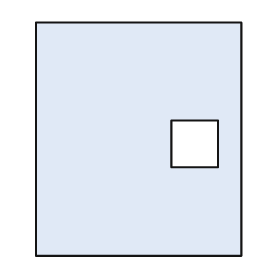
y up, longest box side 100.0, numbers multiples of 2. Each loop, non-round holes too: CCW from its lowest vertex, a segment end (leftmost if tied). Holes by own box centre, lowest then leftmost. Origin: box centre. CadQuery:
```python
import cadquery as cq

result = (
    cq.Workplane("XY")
    .moveTo(-44.0, -50.0)
    .lineTo(44.0, -50.0)
    .lineTo(44.0, 50.0)
    .lineTo(-44.0, 50.0)
    .close()
    .moveTo(14.0, -12.0)
    .lineTo(34.0, -12.0)
    .lineTo(34.0, 8.0)
    .lineTo(14.0, 8.0)
    .close()
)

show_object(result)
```